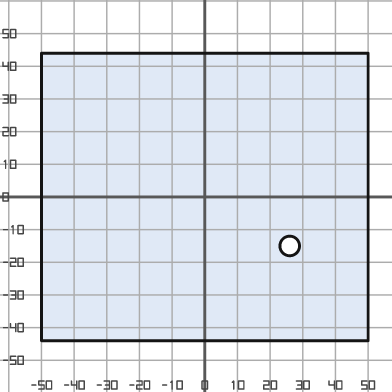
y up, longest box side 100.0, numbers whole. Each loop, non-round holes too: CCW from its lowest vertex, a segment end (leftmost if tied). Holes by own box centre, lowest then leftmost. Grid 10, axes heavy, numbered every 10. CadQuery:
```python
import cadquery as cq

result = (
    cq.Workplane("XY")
    .moveTo(-50.0, -44.0)
    .lineTo(50.0, -44.0)
    .lineTo(50.0, 44.0)
    .lineTo(-50.0, 44.0)
    .close()
    .moveTo(26.0, -15.0)
    .circle(3.0)
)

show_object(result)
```